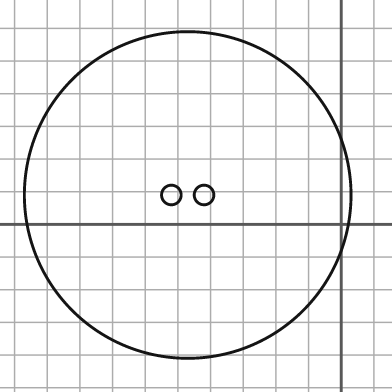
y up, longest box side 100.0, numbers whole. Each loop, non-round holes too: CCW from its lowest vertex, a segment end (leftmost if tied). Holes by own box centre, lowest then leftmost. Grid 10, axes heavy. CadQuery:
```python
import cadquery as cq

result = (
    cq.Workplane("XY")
    .moveTo(-47.0, 9.0)
    .circle(50.0)
    .moveTo(-52.0, 9.0)
    .circle(3.0)
    .moveTo(-42.0, 9.0)
    .circle(3.0)
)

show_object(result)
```